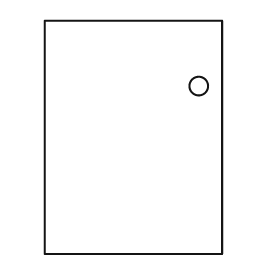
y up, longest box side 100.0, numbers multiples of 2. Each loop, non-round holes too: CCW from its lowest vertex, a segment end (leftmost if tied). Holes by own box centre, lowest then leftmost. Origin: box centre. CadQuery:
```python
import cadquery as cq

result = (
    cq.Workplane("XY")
    .moveTo(-38.0, -50.0)
    .lineTo(38.0, -50.0)
    .lineTo(38.0, 50.0)
    .lineTo(-38.0, 50.0)
    .close()
    .moveTo(28.0, 22.0)
    .circle(4.0)
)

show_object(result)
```